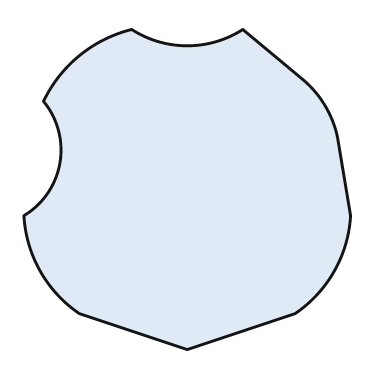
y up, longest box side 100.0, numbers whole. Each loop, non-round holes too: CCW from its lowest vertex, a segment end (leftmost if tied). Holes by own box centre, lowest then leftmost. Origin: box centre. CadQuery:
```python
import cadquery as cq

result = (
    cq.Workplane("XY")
    .moveTo(0.0, -49.0)
    .lineTo(33.0, -38.0)
    .threePointArc((45.0, -25.0), (50.0, -8.0))
    .lineTo(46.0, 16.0)
    .threePointArc((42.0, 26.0), (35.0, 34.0))
    .lineTo(17.0, 49.0)
    .threePointArc((0.0, 44.0), (-17.0, 49.0))
    .threePointArc((-33.0, 41.0), (-44.0, 27.0))
    .threePointArc((-39.0, 8.0), (-50.0, -8.0))
    .threePointArc((-45.0, -25.0), (-33.0, -38.0))
    .close()
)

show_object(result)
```